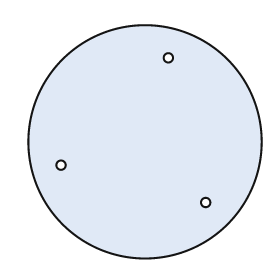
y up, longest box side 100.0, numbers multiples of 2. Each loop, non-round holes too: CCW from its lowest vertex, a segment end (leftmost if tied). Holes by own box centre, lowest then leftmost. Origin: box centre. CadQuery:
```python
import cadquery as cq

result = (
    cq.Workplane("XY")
    .moveTo(0.0, 0.0)
    .circle(50.0)
    .moveTo(26.0, -26.0)
    .circle(2.0)
    .moveTo(-36.0, -10.0)
    .circle(2.0)
    .moveTo(10.0, 36.0)
    .circle(2.0)
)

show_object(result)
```